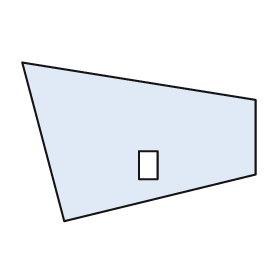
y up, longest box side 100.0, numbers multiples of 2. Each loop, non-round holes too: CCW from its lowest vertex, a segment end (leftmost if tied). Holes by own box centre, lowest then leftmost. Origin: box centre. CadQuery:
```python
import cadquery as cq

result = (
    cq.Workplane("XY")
    .moveTo(-32.0, -34.0)
    .lineTo(50.0, -14.0)
    .lineTo(50.0, 18.0)
    .lineTo(-50.0, 34.0)
    .close()
    .moveTo(0.0, -16.0)
    .lineTo(8.0, -16.0)
    .lineTo(8.0, -4.0)
    .lineTo(0.0, -4.0)
    .close()
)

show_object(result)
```